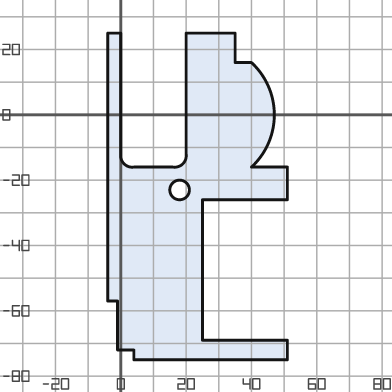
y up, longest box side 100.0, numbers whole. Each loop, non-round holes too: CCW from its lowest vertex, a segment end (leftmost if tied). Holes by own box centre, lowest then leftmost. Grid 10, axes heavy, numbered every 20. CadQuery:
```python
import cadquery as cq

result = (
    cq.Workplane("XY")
    .moveTo(4.0, -75.0)
    .lineTo(51.0, -75.0)
    .lineTo(51.0, -69.0)
    .lineTo(25.0, -69.0)
    .lineTo(25.0, -26.0)
    .lineTo(51.0, -26.0)
    .lineTo(51.0, -16.0)
    .lineTo(40.0, -16.0)
    .threePointArc((47.0, 0.0), (40.0, 16.0))
    .lineTo(35.0, 16.0)
    .lineTo(35.0, 25.0)
    .lineTo(20.0, 25.0)
    .lineTo(20.0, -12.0)
    .threePointArc((19.0, -15.0), (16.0, -16.0))
    .lineTo(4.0, -16.0)
    .threePointArc((1.0, -15.0), (0.0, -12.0))
    .lineTo(0.0, 25.0)
    .lineTo(-4.0, 25.0)
    .lineTo(-4.0, -57.0)
    .lineTo(-1.0, -57.0)
    .lineTo(-1.0, -72.0)
    .lineTo(4.0, -72.0)
    .close()
    .moveTo(18.0, -23.0)
    .circle(3.0)
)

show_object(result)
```